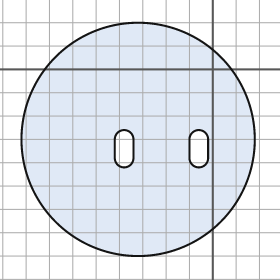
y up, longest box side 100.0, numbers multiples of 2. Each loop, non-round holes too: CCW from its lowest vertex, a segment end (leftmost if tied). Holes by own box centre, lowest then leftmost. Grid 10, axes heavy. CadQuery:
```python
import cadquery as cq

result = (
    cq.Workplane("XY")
    .moveTo(-32.0, -30.0)
    .circle(50.0)
    .moveTo(-42.0, -38.0)
    .threePointArc((-38.0, -42.0), (-34.0, -38.0))
    .lineTo(-34.0, -30.0)
    .threePointArc((-38.0, -26.0), (-42.0, -30.0))
    .close()
    .moveTo(-10.0, -38.0)
    .threePointArc((-6.0, -42.0), (-2.0, -38.0))
    .lineTo(-2.0, -30.0)
    .threePointArc((-6.0, -26.0), (-10.0, -30.0))
    .close()
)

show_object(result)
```